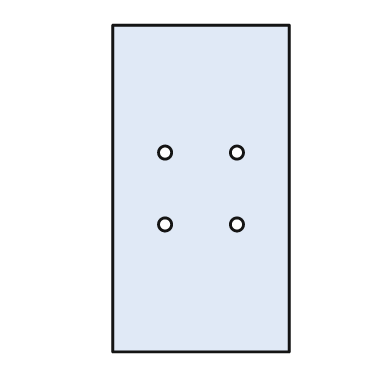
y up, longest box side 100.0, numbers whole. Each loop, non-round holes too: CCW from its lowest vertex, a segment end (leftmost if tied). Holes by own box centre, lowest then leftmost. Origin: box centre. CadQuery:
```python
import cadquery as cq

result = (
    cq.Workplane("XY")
    .moveTo(-27.0, -50.0)
    .lineTo(27.0, -50.0)
    .lineTo(27.0, 50.0)
    .lineTo(-27.0, 50.0)
    .close()
    .moveTo(-11.0, -11.0)
    .circle(2.0)
    .moveTo(11.0, -11.0)
    .circle(2.0)
    .moveTo(-11.0, 11.0)
    .circle(2.0)
    .moveTo(11.0, 11.0)
    .circle(2.0)
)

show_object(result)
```